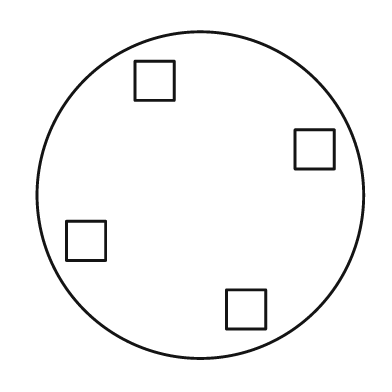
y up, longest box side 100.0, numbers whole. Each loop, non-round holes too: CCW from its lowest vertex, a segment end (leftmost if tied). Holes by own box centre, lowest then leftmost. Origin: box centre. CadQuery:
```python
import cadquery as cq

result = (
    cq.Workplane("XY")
    .moveTo(0.0, 0.0)
    .circle(50.0)
    .moveTo(8.0, -41.0)
    .lineTo(20.0, -41.0)
    .lineTo(20.0, -29.0)
    .lineTo(8.0, -29.0)
    .close()
    .moveTo(-41.0, -20.0)
    .lineTo(-29.0, -20.0)
    .lineTo(-29.0, -8.0)
    .lineTo(-41.0, -8.0)
    .close()
    .moveTo(29.0, 8.0)
    .lineTo(41.0, 8.0)
    .lineTo(41.0, 20.0)
    .lineTo(29.0, 20.0)
    .close()
    .moveTo(-20.0, 29.0)
    .lineTo(-8.0, 29.0)
    .lineTo(-8.0, 41.0)
    .lineTo(-20.0, 41.0)
    .close()
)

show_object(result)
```